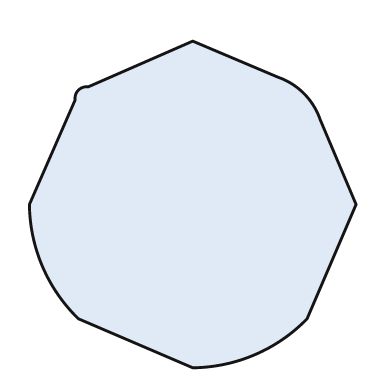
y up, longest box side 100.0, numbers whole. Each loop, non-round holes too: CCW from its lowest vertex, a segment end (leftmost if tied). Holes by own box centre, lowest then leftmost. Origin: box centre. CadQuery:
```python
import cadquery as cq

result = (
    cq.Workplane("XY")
    .moveTo(0.0, -50.0)
    .threePointArc((19.0, -46.0), (35.0, -35.0))
    .lineTo(50.0, 0.0)
    .lineTo(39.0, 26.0)
    .threePointArc((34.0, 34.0), (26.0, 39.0))
    .lineTo(0.0, 50.0)
    .lineTo(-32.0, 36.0)
    .threePointArc((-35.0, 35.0), (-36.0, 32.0))
    .lineTo(-50.0, 0.0)
    .threePointArc((-46.0, -19.0), (-35.0, -35.0))
    .close()
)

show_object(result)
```